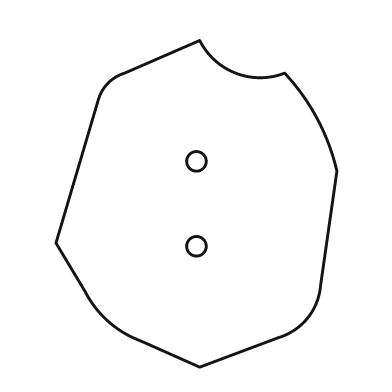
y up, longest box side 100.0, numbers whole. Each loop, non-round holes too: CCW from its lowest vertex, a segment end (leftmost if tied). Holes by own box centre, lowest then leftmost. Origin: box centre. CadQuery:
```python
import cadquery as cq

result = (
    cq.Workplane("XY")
    .moveTo(1.0, -50.0)
    .lineTo(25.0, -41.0)
    .threePointArc((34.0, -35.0), (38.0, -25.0))
    .lineTo(43.0, 10.0)
    .threePointArc((37.0, 26.0), (27.0, 40.0))
    .threePointArc((12.0, 40.0), (1.0, 50.0))
    .lineTo(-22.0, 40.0)
    .threePointArc((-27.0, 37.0), (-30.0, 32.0))
    .lineTo(-43.0, -12.0)
    .lineTo(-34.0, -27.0)
    .threePointArc((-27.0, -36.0), (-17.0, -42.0))
    .close()
    .moveTo(0.0, -13.0)
    .circle(3.0)
    .moveTo(0.0, 13.0)
    .circle(3.0)
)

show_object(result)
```